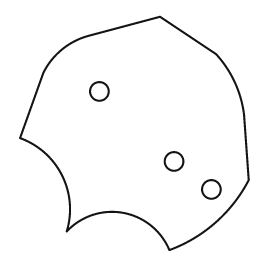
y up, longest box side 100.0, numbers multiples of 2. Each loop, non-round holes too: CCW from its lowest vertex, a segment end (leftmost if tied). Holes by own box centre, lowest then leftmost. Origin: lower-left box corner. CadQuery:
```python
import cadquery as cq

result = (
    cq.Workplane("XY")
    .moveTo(64.0, 0.0)
    .threePointArc((84.0, 12.0), (98.0, 30.0))
    .lineTo(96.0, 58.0)
    .threePointArc((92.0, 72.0), (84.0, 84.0))
    .lineTo(60.0, 100.0)
    .lineTo(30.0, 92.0)
    .threePointArc((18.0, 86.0), (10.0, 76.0))
    .lineTo(0.0, 48.0)
    .threePointArc((18.0, 32.0), (20.0, 8.0))
    .threePointArc((44.0, 16.0), (64.0, 0.0))
    .close()
    .moveTo(82.0, 26.0)
    .circle(4.0)
    .moveTo(66.0, 38.0)
    .circle(4.0)
    .moveTo(34.0, 68.0)
    .circle(4.0)
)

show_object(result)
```